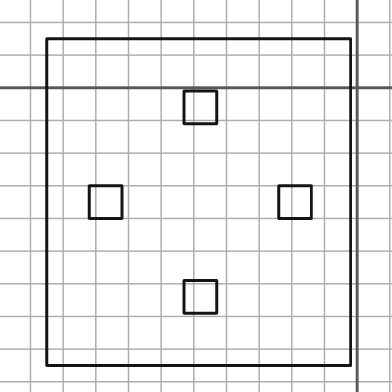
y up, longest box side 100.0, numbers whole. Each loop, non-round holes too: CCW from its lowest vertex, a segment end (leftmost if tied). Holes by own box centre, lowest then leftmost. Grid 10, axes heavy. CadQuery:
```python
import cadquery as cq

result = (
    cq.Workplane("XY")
    .moveTo(-95.0, -85.0)
    .lineTo(-2.0, -85.0)
    .lineTo(-2.0, 15.0)
    .lineTo(-95.0, 15.0)
    .close()
    .moveTo(-53.0, -69.0)
    .lineTo(-43.0, -69.0)
    .lineTo(-43.0, -59.0)
    .lineTo(-53.0, -59.0)
    .close()
    .moveTo(-82.0, -40.0)
    .lineTo(-72.0, -40.0)
    .lineTo(-72.0, -30.0)
    .lineTo(-82.0, -30.0)
    .close()
    .moveTo(-24.0, -40.0)
    .lineTo(-14.0, -40.0)
    .lineTo(-14.0, -30.0)
    .lineTo(-24.0, -30.0)
    .close()
    .moveTo(-53.0, -11.0)
    .lineTo(-43.0, -11.0)
    .lineTo(-43.0, -1.0)
    .lineTo(-53.0, -1.0)
    .close()
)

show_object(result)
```